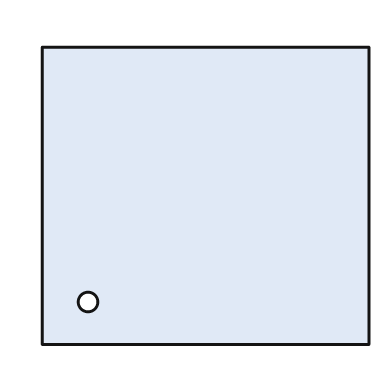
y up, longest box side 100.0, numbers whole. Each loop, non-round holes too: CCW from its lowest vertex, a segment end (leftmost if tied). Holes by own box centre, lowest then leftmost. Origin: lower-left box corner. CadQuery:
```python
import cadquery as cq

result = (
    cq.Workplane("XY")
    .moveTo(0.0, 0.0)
    .lineTo(100.0, 0.0)
    .lineTo(100.0, 91.0)
    .lineTo(0.0, 91.0)
    .close()
    .moveTo(14.0, 13.0)
    .circle(3.0)
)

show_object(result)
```